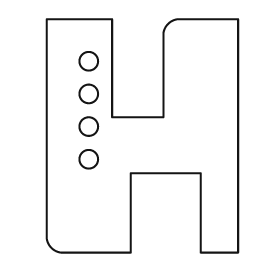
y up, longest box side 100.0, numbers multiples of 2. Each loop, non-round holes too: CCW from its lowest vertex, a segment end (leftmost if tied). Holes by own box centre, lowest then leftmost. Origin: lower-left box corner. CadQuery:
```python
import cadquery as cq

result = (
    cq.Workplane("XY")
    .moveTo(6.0, 0.0)
    .lineTo(36.0, 0.0)
    .lineTo(36.0, 34.0)
    .lineTo(66.0, 34.0)
    .lineTo(66.0, 0.0)
    .lineTo(82.0, 0.0)
    .lineTo(82.0, 100.0)
    .lineTo(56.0, 100.0)
    .threePointArc((52.0, 98.0), (50.0, 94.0))
    .lineTo(50.0, 58.0)
    .lineTo(28.0, 58.0)
    .lineTo(28.0, 100.0)
    .lineTo(0.0, 100.0)
    .lineTo(0.0, 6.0)
    .threePointArc((2.0, 2.0), (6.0, 0.0))
    .close()
    .moveTo(18.0, 40.0)
    .circle(4.0)
    .moveTo(18.0, 54.0)
    .circle(4.0)
    .moveTo(18.0, 68.0)
    .circle(4.0)
    .moveTo(18.0, 82.0)
    .circle(4.0)
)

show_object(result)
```